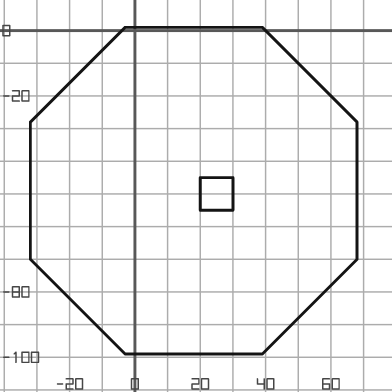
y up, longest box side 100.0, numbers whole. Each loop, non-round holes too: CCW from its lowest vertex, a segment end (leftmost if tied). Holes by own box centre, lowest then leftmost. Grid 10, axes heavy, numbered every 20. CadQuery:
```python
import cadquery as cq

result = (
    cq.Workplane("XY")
    .moveTo(-3.0, -99.0)
    .lineTo(39.0, -99.0)
    .lineTo(68.0, -70.0)
    .lineTo(68.0, -28.0)
    .lineTo(39.0, 1.0)
    .lineTo(-3.0, 1.0)
    .lineTo(-32.0, -28.0)
    .lineTo(-32.0, -70.0)
    .close()
    .moveTo(20.0, -55.0)
    .lineTo(30.0, -55.0)
    .lineTo(30.0, -45.0)
    .lineTo(20.0, -45.0)
    .close()
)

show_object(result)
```